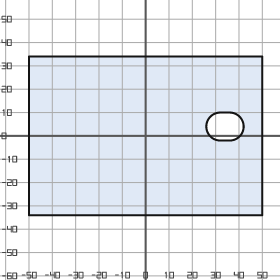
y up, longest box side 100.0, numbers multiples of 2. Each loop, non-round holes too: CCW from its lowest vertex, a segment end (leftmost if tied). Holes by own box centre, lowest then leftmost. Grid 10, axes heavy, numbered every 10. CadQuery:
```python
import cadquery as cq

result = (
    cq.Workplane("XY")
    .moveTo(-50.0, -34.0)
    .lineTo(50.0, -34.0)
    .lineTo(50.0, 34.0)
    .lineTo(-50.0, 34.0)
    .close()
    .moveTo(32.0, -2.0)
    .lineTo(36.0, -2.0)
    .threePointArc((42.0, 4.0), (36.0, 10.0))
    .lineTo(32.0, 10.0)
    .threePointArc((26.0, 4.0), (32.0, -2.0))
    .close()
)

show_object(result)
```